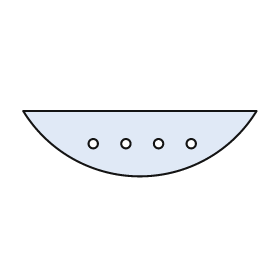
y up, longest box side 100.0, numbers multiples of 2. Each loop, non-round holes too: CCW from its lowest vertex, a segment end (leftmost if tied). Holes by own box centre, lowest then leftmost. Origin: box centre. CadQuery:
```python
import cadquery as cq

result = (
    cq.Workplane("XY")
    .moveTo(-50.0, 14.0)
    .threePointArc((0.0, -14.0), (50.0, 14.0))
    .close()
    .moveTo(-20.0, 0.0)
    .circle(2.0)
    .moveTo(-6.0, 0.0)
    .circle(2.0)
    .moveTo(8.0, 0.0)
    .circle(2.0)
    .moveTo(22.0, 0.0)
    .circle(2.0)
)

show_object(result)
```